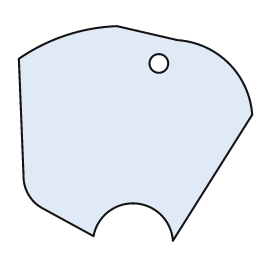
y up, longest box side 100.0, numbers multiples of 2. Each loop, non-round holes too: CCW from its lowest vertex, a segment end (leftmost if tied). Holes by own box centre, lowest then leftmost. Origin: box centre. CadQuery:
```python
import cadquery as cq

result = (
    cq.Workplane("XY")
    .moveTo(16.0, -46.0)
    .lineTo(50.0, 8.0)
    .threePointArc((40.0, 30.0), (18.0, 40.0))
    .lineTo(-8.0, 46.0)
    .threePointArc((-30.0, 42.0), (-50.0, 32.0))
    .lineTo(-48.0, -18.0)
    .threePointArc((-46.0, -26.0), (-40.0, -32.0))
    .lineTo(-18.0, -44.0)
    .threePointArc((0.0, -30.0), (16.0, -46.0))
    .close()
    .moveTo(10.0, 30.0)
    .circle(4.0)
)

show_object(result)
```